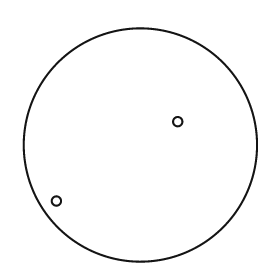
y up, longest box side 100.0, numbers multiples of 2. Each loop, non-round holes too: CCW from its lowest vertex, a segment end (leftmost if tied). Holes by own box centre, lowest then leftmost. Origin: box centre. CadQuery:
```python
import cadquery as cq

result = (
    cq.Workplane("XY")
    .moveTo(0.0, 0.0)
    .circle(50.0)
    .moveTo(-36.0, -24.0)
    .circle(2.0)
    .moveTo(16.0, 10.0)
    .circle(2.0)
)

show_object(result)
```